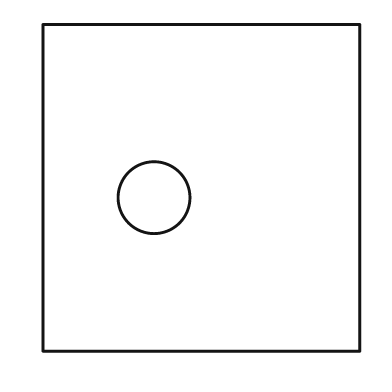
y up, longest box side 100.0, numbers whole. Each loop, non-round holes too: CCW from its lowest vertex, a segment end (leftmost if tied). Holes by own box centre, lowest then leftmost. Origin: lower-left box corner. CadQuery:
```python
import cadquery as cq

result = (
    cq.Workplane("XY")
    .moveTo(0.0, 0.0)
    .lineTo(97.0, 0.0)
    .lineTo(97.0, 100.0)
    .lineTo(0.0, 100.0)
    .close()
    .moveTo(34.0, 47.0)
    .circle(11.0)
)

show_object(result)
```